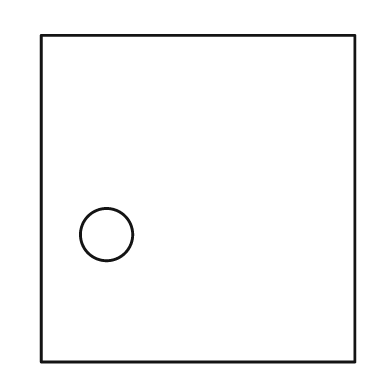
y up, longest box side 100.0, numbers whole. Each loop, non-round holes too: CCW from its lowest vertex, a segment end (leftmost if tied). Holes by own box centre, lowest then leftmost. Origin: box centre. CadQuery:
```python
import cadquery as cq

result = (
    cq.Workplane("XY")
    .moveTo(-48.0, -50.0)
    .lineTo(48.0, -50.0)
    .lineTo(48.0, 50.0)
    .lineTo(-48.0, 50.0)
    .close()
    .moveTo(-28.0, -11.0)
    .circle(8.0)
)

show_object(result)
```